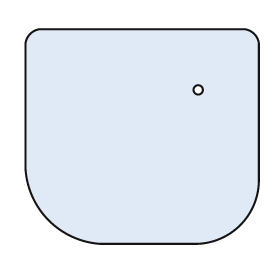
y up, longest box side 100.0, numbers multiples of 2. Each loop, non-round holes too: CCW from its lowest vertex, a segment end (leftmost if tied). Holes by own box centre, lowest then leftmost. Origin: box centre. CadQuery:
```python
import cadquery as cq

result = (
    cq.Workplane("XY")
    .moveTo(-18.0, -46.0)
    .lineTo(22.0, -46.0)
    .threePointArc((42.0, -38.0), (50.0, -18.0))
    .lineTo(50.0, 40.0)
    .threePointArc((48.0, 44.0), (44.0, 46.0))
    .lineTo(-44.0, 46.0)
    .threePointArc((-48.0, 44.0), (-50.0, 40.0))
    .lineTo(-50.0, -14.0)
    .threePointArc((-40.0, -36.0), (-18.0, -46.0))
    .close()
    .moveTo(24.0, 20.0)
    .circle(2.0)
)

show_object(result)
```